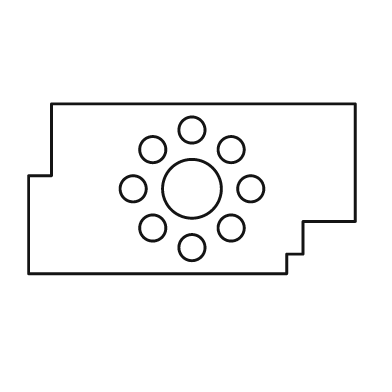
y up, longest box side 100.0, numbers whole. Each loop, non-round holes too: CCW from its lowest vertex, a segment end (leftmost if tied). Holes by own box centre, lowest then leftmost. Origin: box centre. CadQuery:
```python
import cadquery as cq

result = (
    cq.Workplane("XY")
    .moveTo(-50.0, -26.0)
    .lineTo(29.0, -26.0)
    .lineTo(29.0, -20.0)
    .lineTo(34.0, -20.0)
    .lineTo(34.0, -10.0)
    .lineTo(50.0, -10.0)
    .lineTo(50.0, 26.0)
    .lineTo(-43.0, 26.0)
    .lineTo(-43.0, 4.0)
    .lineTo(-50.0, 4.0)
    .close()
    .moveTo(0.0, -18.0)
    .circle(4.0)
    .moveTo(-12.0, -12.0)
    .circle(4.0)
    .moveTo(12.0, -12.0)
    .circle(4.0)
    .moveTo(-18.0, 0.0)
    .circle(4.0)
    .moveTo(0.0, 0.0)
    .circle(9.0)
    .moveTo(18.0, 0.0)
    .circle(4.0)
    .moveTo(-12.0, 12.0)
    .circle(4.0)
    .moveTo(12.0, 12.0)
    .circle(4.0)
    .moveTo(0.0, 18.0)
    .circle(4.0)
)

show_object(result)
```